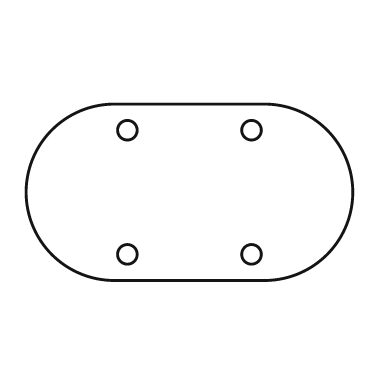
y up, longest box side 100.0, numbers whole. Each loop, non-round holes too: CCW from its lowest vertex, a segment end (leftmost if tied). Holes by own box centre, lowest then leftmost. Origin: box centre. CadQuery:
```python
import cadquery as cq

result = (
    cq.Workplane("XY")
    .moveTo(-23.0, -27.0)
    .lineTo(23.0, -27.0)
    .threePointArc((50.0, 0.0), (23.0, 27.0))
    .lineTo(-23.0, 27.0)
    .threePointArc((-50.0, 0.0), (-23.0, -27.0))
    .close()
    .moveTo(-19.0, -19.0)
    .circle(3.0)
    .moveTo(19.0, -19.0)
    .circle(3.0)
    .moveTo(-19.0, 19.0)
    .circle(3.0)
    .moveTo(19.0, 19.0)
    .circle(3.0)
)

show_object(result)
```